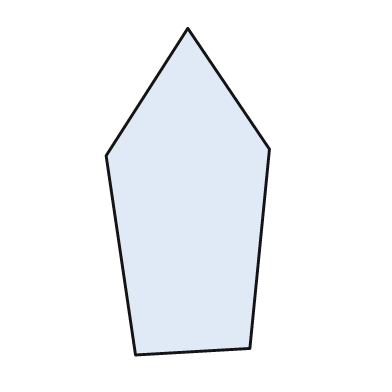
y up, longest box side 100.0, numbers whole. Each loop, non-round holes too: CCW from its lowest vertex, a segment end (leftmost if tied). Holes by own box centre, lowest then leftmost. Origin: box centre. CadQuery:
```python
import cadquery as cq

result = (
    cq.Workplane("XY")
    .moveTo(-16.0, -50.0)
    .lineTo(19.0, -48.0)
    .lineTo(25.0, 13.0)
    .lineTo(0.0, 50.0)
    .lineTo(-25.0, 11.0)
    .close()
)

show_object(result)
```